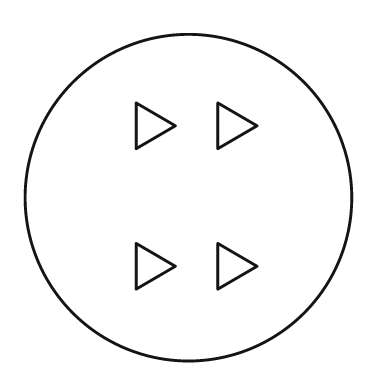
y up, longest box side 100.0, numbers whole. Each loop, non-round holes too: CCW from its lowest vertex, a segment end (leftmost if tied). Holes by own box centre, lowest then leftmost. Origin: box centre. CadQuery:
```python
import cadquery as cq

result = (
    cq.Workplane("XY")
    .moveTo(0.0, 0.0)
    .circle(50.0)
    .moveTo(-16.0, -28.0)
    .lineTo(-4.0, -21.0)
    .lineTo(-16.0, -14.0)
    .close()
    .moveTo(9.0, -28.0)
    .lineTo(21.0, -21.0)
    .lineTo(9.0, -14.0)
    .close()
    .moveTo(-16.0, 15.0)
    .lineTo(-4.0, 22.0)
    .lineTo(-16.0, 29.0)
    .close()
    .moveTo(9.0, 15.0)
    .lineTo(21.0, 22.0)
    .lineTo(9.0, 29.0)
    .close()
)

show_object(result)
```